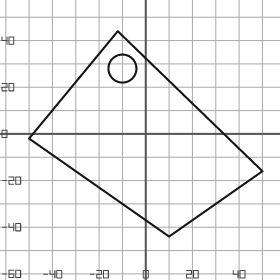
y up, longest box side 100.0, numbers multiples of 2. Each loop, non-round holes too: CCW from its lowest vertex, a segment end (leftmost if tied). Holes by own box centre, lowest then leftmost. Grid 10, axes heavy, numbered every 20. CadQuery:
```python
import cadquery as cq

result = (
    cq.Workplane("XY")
    .moveTo(10.0, -44.0)
    .lineTo(50.0, -16.0)
    .lineTo(-12.0, 44.0)
    .lineTo(-50.0, -2.0)
    .close()
    .moveTo(-10.0, 28.0)
    .circle(6.0)
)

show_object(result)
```